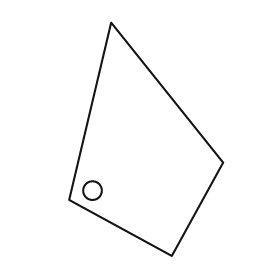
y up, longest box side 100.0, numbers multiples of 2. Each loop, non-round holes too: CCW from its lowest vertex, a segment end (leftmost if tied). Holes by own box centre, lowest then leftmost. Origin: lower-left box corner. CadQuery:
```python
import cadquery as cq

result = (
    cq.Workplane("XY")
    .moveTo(44.0, 0.0)
    .lineTo(66.0, 40.0)
    .lineTo(18.0, 100.0)
    .lineTo(0.0, 24.0)
    .close()
    .moveTo(10.0, 28.0)
    .circle(4.0)
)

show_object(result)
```